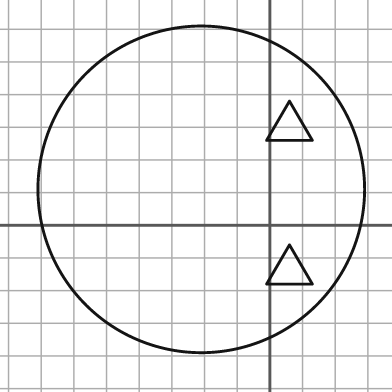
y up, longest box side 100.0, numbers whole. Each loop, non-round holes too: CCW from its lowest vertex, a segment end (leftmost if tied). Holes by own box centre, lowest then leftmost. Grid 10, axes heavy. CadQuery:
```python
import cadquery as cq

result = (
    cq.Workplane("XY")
    .moveTo(-21.0, 11.0)
    .circle(50.0)
    .moveTo(-1.0, -18.0)
    .lineTo(13.0, -18.0)
    .lineTo(6.0, -6.0)
    .close()
    .moveTo(-1.0, 26.0)
    .lineTo(13.0, 26.0)
    .lineTo(6.0, 38.0)
    .close()
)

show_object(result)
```